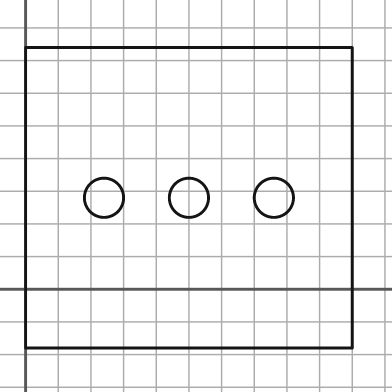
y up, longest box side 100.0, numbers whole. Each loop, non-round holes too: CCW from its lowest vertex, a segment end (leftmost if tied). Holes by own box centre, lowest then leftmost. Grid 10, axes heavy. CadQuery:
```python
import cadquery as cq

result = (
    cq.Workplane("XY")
    .moveTo(0.0, -18.0)
    .lineTo(100.0, -18.0)
    .lineTo(100.0, 74.0)
    .lineTo(0.0, 74.0)
    .close()
    .moveTo(24.0, 28.0)
    .circle(6.0)
    .moveTo(50.0, 28.0)
    .circle(6.0)
    .moveTo(76.0, 28.0)
    .circle(6.0)
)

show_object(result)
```